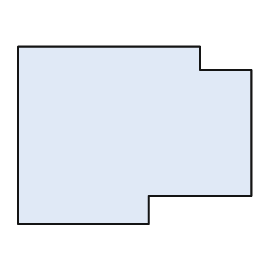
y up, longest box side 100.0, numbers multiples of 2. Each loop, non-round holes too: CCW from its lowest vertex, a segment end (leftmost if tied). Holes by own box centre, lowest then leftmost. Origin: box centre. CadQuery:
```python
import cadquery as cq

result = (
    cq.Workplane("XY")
    .moveTo(-50.0, -38.0)
    .lineTo(6.0, -38.0)
    .lineTo(6.0, -26.0)
    .lineTo(50.0, -26.0)
    .lineTo(50.0, 28.0)
    .lineTo(28.0, 28.0)
    .lineTo(28.0, 38.0)
    .lineTo(-50.0, 38.0)
    .close()
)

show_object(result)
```